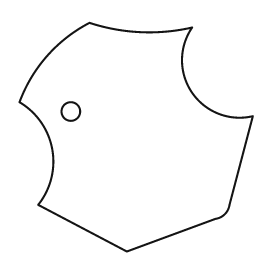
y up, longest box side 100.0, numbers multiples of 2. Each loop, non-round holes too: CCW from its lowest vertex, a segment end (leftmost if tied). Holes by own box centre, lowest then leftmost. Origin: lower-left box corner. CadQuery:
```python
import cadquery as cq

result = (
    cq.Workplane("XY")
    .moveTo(46.0, 0.0)
    .lineTo(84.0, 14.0)
    .threePointArc((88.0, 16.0), (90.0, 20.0))
    .lineTo(100.0, 58.0)
    .threePointArc((74.0, 68.0), (74.0, 96.0))
    .threePointArc((52.0, 94.0), (30.0, 98.0))
    .threePointArc((12.0, 84.0), (0.0, 64.0))
    .threePointArc((14.0, 44.0), (8.0, 20.0))
    .close()
    .moveTo(22.0, 60.0)
    .circle(4.0)
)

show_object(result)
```